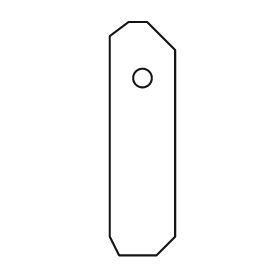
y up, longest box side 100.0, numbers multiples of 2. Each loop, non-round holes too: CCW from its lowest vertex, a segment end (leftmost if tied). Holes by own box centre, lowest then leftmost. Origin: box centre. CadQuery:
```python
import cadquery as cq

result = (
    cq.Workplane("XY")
    .moveTo(-10.0, -50.0)
    .lineTo(6.0, -50.0)
    .lineTo(14.0, -42.0)
    .lineTo(14.0, 38.0)
    .lineTo(2.0, 50.0)
    .lineTo(-6.0, 50.0)
    .lineTo(-14.0, 44.0)
    .lineTo(-14.0, -42.0)
    .close()
    .moveTo(0.0, 26.0)
    .circle(4.0)
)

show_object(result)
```